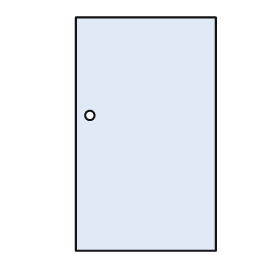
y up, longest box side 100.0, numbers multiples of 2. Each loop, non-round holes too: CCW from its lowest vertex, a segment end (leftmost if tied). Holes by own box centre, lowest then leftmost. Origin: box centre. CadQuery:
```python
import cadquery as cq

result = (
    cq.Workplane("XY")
    .moveTo(-30.0, -50.0)
    .lineTo(30.0, -50.0)
    .lineTo(30.0, 50.0)
    .lineTo(-30.0, 50.0)
    .close()
    .moveTo(-24.0, 8.0)
    .circle(2.0)
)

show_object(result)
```